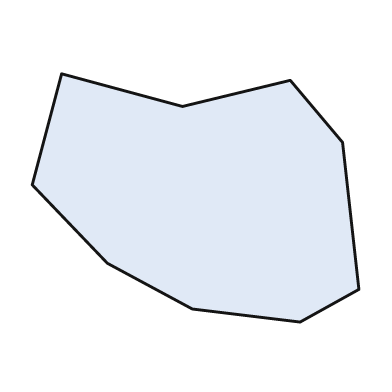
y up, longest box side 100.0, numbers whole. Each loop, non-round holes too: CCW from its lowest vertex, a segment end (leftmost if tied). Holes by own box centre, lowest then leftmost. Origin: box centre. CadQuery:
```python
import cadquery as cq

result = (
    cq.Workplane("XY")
    .moveTo(32.0, -38.0)
    .lineTo(50.0, -28.0)
    .lineTo(45.0, 17.0)
    .lineTo(29.0, 36.0)
    .lineTo(-4.0, 28.0)
    .lineTo(-41.0, 38.0)
    .lineTo(-50.0, 4.0)
    .lineTo(-27.0, -20.0)
    .lineTo(-1.0, -34.0)
    .close()
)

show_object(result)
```